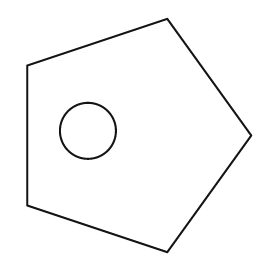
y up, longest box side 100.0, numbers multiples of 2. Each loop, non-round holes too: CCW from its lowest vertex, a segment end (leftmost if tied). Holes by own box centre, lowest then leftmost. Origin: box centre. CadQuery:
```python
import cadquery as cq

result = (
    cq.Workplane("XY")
    .moveTo(12.0, -50.0)
    .lineTo(48.0, 0.0)
    .lineTo(12.0, 50.0)
    .lineTo(-48.0, 30.0)
    .lineTo(-48.0, -30.0)
    .close()
    .moveTo(-22.0, 2.0)
    .circle(12.0)
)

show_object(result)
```